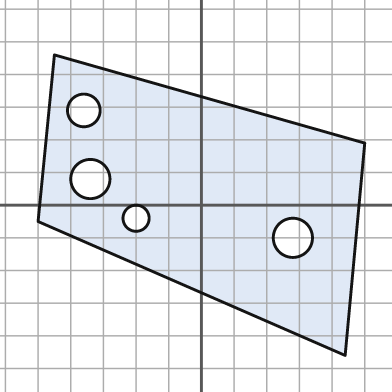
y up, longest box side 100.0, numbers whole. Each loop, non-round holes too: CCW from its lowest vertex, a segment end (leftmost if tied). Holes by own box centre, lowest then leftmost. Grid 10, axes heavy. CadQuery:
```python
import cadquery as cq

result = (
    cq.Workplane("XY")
    .moveTo(44.0, -46.0)
    .lineTo(50.0, 19.0)
    .lineTo(-45.0, 46.0)
    .lineTo(-50.0, -5.0)
    .close()
    .moveTo(28.0, -10.0)
    .circle(6.0)
    .moveTo(-20.0, -4.0)
    .circle(4.0)
    .moveTo(-34.0, 8.0)
    .circle(6.0)
    .moveTo(-36.0, 29.0)
    .circle(5.0)
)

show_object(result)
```